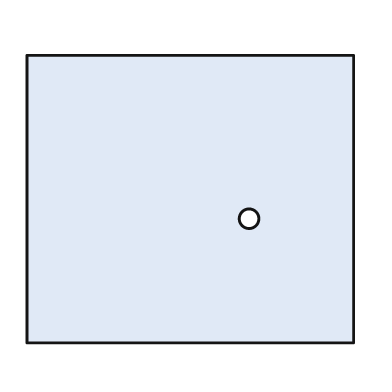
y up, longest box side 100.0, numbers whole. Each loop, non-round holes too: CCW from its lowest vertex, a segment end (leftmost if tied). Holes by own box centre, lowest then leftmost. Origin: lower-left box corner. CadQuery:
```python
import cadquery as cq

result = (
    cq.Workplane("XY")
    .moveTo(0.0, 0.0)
    .lineTo(100.0, 0.0)
    .lineTo(100.0, 88.0)
    .lineTo(0.0, 88.0)
    .close()
    .moveTo(68.0, 38.0)
    .circle(3.0)
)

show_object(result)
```